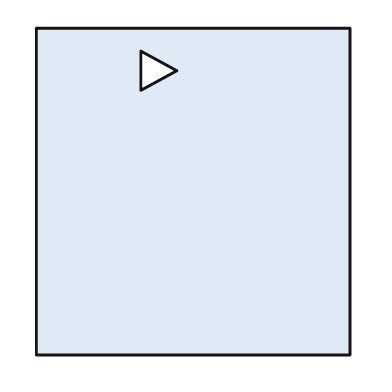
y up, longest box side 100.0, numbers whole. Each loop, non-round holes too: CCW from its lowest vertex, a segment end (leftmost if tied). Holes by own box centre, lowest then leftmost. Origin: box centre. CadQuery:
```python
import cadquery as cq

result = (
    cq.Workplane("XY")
    .moveTo(-48.0, -50.0)
    .lineTo(48.0, -50.0)
    .lineTo(48.0, 50.0)
    .lineTo(-48.0, 50.0)
    .close()
    .moveTo(-16.0, 31.0)
    .lineTo(-5.0, 37.0)
    .lineTo(-16.0, 43.0)
    .close()
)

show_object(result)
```